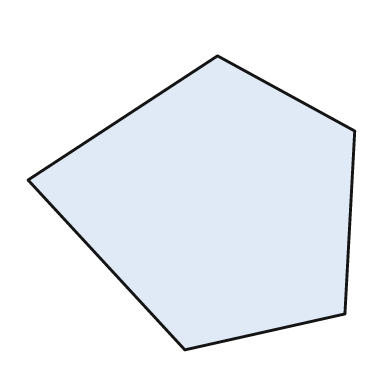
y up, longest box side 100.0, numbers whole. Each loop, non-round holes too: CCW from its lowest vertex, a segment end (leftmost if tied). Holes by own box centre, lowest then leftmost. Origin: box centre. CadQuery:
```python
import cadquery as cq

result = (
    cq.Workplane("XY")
    .moveTo(-2.0, -45.0)
    .lineTo(47.0, -34.0)
    .lineTo(50.0, 22.0)
    .lineTo(8.0, 45.0)
    .lineTo(-50.0, 7.0)
    .close()
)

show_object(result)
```